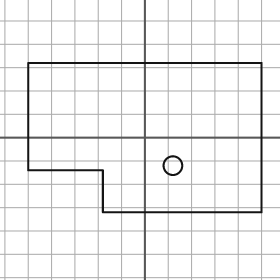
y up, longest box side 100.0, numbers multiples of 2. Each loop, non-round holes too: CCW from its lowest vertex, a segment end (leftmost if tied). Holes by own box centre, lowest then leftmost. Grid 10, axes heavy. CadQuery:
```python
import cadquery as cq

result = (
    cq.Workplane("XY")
    .moveTo(-18.0, -32.0)
    .lineTo(50.0, -32.0)
    .lineTo(50.0, 32.0)
    .lineTo(-50.0, 32.0)
    .lineTo(-50.0, -14.0)
    .lineTo(-18.0, -14.0)
    .close()
    .moveTo(12.0, -12.0)
    .circle(4.0)
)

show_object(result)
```